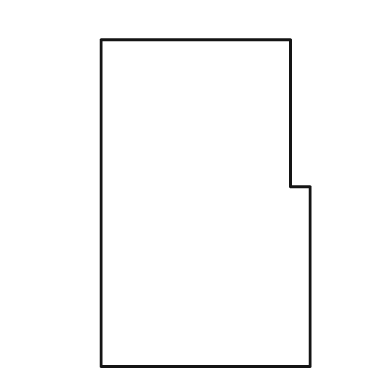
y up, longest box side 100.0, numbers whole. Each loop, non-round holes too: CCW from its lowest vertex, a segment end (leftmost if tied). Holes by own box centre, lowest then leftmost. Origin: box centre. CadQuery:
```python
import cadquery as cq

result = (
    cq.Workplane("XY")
    .moveTo(-32.0, -50.0)
    .lineTo(32.0, -50.0)
    .lineTo(32.0, 5.0)
    .lineTo(26.0, 5.0)
    .lineTo(26.0, 50.0)
    .lineTo(-32.0, 50.0)
    .close()
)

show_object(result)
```